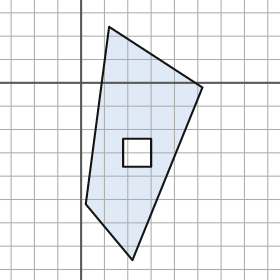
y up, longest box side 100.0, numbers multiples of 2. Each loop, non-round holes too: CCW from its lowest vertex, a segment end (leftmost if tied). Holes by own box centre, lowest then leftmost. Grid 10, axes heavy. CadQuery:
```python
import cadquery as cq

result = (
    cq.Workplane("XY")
    .moveTo(22.0, -76.0)
    .lineTo(52.0, -2.0)
    .lineTo(12.0, 24.0)
    .lineTo(2.0, -52.0)
    .close()
    .moveTo(18.0, -36.0)
    .lineTo(30.0, -36.0)
    .lineTo(30.0, -24.0)
    .lineTo(18.0, -24.0)
    .close()
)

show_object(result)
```